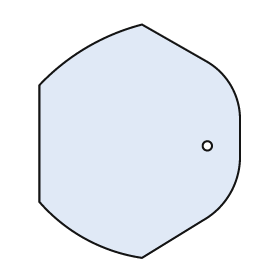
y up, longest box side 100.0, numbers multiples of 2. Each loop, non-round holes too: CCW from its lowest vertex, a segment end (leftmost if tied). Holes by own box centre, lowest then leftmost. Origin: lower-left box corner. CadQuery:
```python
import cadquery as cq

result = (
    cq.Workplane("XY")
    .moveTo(44.0, 0.0)
    .lineTo(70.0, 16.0)
    .threePointArc((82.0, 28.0), (86.0, 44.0))
    .lineTo(86.0, 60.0)
    .threePointArc((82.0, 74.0), (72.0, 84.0))
    .lineTo(44.0, 100.0)
    .threePointArc((20.0, 90.0), (0.0, 74.0))
    .lineTo(0.0, 24.0)
    .threePointArc((20.0, 8.0), (44.0, 0.0))
    .close()
    .moveTo(72.0, 48.0)
    .circle(2.0)
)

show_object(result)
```